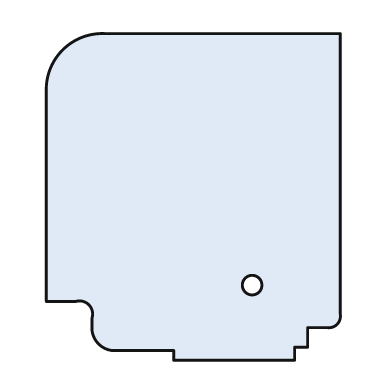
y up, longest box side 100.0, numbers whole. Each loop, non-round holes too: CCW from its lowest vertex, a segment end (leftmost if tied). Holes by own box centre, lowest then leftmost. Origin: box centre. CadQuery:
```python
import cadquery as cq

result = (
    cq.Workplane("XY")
    .moveTo(-6.0, -50.0)
    .lineTo(31.0, -50.0)
    .lineTo(31.0, -46.0)
    .lineTo(35.0, -46.0)
    .lineTo(35.0, -40.0)
    .lineTo(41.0, -40.0)
    .threePointArc((44.0, -39.0), (45.0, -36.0))
    .lineTo(45.0, 50.0)
    .lineTo(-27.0, 50.0)
    .threePointArc((-40.0, 45.0), (-45.0, 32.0))
    .lineTo(-45.0, -32.0)
    .lineTo(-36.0, -32.0)
    .threePointArc((-32.0, -33.0), (-31.0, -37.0))
    .lineTo(-31.0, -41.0)
    .threePointArc((-29.0, -45.0), (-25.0, -47.0))
    .lineTo(-6.0, -47.0)
    .close()
    .moveTo(18.0, -27.0)
    .circle(3.0)
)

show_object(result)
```